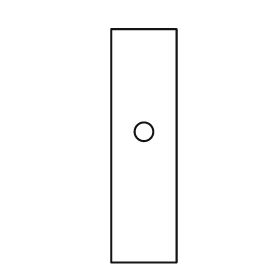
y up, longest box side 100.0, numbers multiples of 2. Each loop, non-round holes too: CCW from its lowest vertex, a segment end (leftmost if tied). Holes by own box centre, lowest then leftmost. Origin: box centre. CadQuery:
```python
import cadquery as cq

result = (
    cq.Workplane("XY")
    .moveTo(-14.0, -50.0)
    .lineTo(14.0, -50.0)
    .lineTo(14.0, 50.0)
    .lineTo(-14.0, 50.0)
    .close()
    .moveTo(0.0, 6.0)
    .circle(4.0)
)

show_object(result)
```